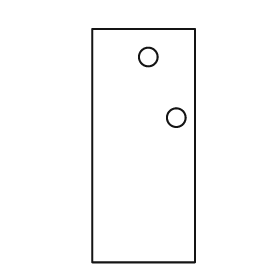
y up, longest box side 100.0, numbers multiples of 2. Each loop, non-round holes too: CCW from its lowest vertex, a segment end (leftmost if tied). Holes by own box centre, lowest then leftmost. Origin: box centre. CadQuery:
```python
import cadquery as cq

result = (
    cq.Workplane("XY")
    .moveTo(-22.0, -50.0)
    .lineTo(22.0, -50.0)
    .lineTo(22.0, 50.0)
    .lineTo(-22.0, 50.0)
    .close()
    .moveTo(14.0, 12.0)
    .circle(4.0)
    .moveTo(2.0, 38.0)
    .circle(4.0)
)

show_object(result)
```